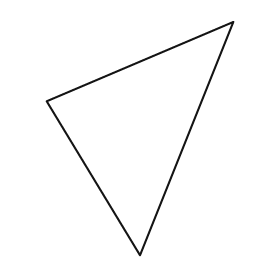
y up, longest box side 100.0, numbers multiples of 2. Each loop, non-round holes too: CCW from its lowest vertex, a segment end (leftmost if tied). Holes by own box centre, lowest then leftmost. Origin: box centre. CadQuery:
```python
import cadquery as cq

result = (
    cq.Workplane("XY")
    .moveTo(0.0, -50.0)
    .lineTo(40.0, 50.0)
    .lineTo(-40.0, 16.0)
    .close()
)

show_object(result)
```